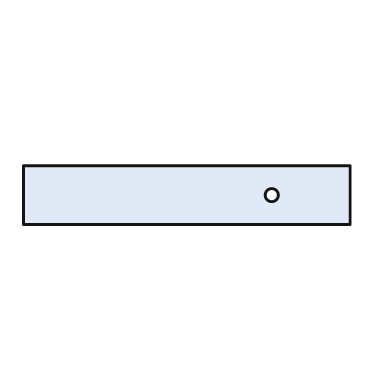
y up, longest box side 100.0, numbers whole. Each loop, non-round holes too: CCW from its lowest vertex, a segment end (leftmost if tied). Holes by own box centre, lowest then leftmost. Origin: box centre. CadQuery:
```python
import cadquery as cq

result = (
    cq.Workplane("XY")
    .moveTo(-50.0, -9.0)
    .lineTo(50.0, -9.0)
    .lineTo(50.0, 9.0)
    .lineTo(-50.0, 9.0)
    .close()
    .moveTo(26.0, 0.0)
    .circle(2.0)
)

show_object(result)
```